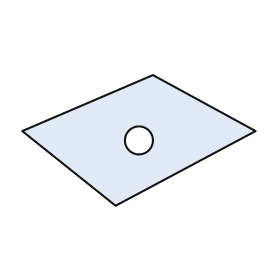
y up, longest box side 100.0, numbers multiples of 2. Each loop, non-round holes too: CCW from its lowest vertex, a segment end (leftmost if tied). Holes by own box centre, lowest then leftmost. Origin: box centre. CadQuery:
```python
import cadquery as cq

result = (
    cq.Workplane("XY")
    .moveTo(-10.0, -28.0)
    .lineTo(50.0, 4.0)
    .lineTo(6.0, 28.0)
    .lineTo(-50.0, 4.0)
    .close()
    .moveTo(0.0, 0.0)
    .circle(6.0)
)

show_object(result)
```